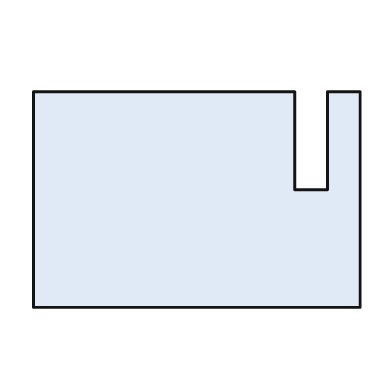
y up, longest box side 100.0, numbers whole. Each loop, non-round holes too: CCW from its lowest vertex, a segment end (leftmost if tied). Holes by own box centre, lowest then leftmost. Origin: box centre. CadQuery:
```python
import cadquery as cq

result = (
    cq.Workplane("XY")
    .moveTo(-50.0, -33.0)
    .lineTo(50.0, -33.0)
    .lineTo(50.0, 33.0)
    .lineTo(40.0, 33.0)
    .lineTo(40.0, 3.0)
    .lineTo(30.0, 3.0)
    .lineTo(30.0, 33.0)
    .lineTo(-50.0, 33.0)
    .close()
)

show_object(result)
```